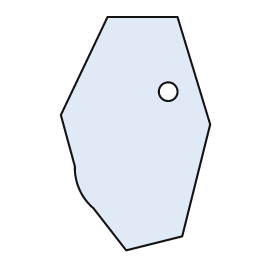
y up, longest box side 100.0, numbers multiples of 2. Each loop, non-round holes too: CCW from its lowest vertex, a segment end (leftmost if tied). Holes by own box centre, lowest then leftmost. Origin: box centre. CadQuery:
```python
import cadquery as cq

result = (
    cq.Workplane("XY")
    .moveTo(-4.0, -50.0)
    .lineTo(20.0, -44.0)
    .lineTo(32.0, 4.0)
    .lineTo(18.0, 50.0)
    .lineTo(-12.0, 50.0)
    .lineTo(-32.0, 8.0)
    .lineTo(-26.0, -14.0)
    .threePointArc((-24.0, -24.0), (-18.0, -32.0))
    .close()
    .moveTo(14.0, 18.0)
    .circle(4.0)
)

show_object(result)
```